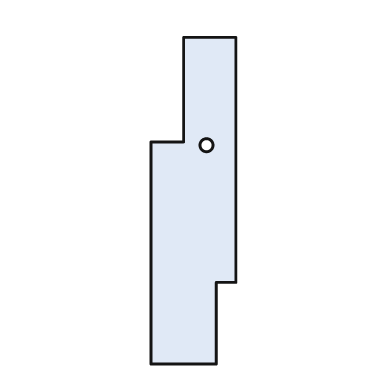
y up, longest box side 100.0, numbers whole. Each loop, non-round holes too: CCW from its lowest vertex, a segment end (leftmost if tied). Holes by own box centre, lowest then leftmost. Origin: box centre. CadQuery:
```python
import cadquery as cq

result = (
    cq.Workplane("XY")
    .moveTo(-13.0, -50.0)
    .lineTo(7.0, -50.0)
    .lineTo(7.0, -25.0)
    .lineTo(13.0, -25.0)
    .lineTo(13.0, 50.0)
    .lineTo(-3.0, 50.0)
    .lineTo(-3.0, 18.0)
    .lineTo(-13.0, 18.0)
    .close()
    .moveTo(4.0, 17.0)
    .circle(2.0)
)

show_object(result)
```